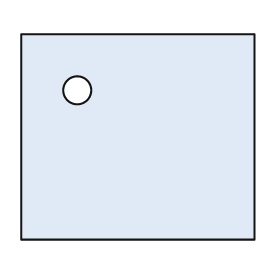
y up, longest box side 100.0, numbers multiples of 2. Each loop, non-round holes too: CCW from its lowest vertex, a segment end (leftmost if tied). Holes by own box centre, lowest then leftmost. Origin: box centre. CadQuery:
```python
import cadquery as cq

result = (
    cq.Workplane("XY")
    .moveTo(-50.0, -44.0)
    .lineTo(50.0, -44.0)
    .lineTo(50.0, 44.0)
    .lineTo(-50.0, 44.0)
    .close()
    .moveTo(-26.0, 20.0)
    .circle(6.0)
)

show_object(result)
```